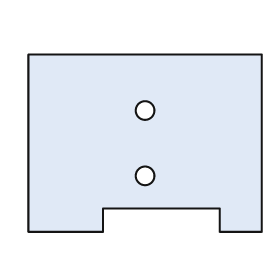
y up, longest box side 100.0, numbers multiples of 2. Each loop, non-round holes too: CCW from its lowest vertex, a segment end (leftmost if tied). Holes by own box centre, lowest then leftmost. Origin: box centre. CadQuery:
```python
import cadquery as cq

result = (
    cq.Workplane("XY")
    .moveTo(-50.0, -38.0)
    .lineTo(-18.0, -38.0)
    .lineTo(-18.0, -28.0)
    .lineTo(32.0, -28.0)
    .lineTo(32.0, -38.0)
    .lineTo(50.0, -38.0)
    .lineTo(50.0, 38.0)
    .lineTo(-50.0, 38.0)
    .close()
    .moveTo(0.0, -14.0)
    .circle(4.0)
    .moveTo(0.0, 14.0)
    .circle(4.0)
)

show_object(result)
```